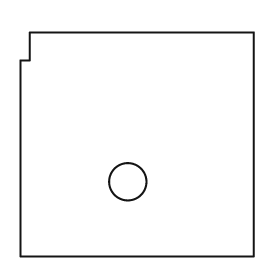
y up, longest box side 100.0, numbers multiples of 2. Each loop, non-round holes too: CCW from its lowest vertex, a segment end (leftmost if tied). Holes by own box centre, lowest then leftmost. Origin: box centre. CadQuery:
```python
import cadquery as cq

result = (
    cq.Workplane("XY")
    .moveTo(-50.0, -48.0)
    .lineTo(50.0, -48.0)
    .lineTo(50.0, 48.0)
    .lineTo(-46.0, 48.0)
    .lineTo(-46.0, 36.0)
    .lineTo(-50.0, 36.0)
    .close()
    .moveTo(-4.0, -16.0)
    .circle(8.0)
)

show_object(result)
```